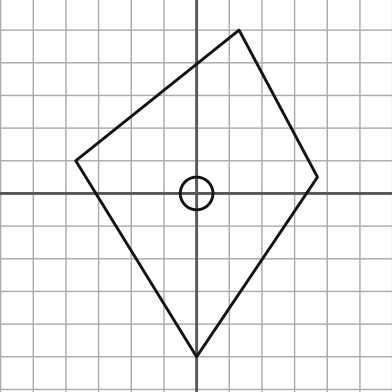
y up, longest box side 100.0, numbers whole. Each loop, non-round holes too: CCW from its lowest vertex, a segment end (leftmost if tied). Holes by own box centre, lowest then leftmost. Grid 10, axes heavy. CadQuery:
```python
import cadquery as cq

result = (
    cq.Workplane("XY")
    .moveTo(0.0, -50.0)
    .lineTo(37.0, 5.0)
    .lineTo(13.0, 50.0)
    .lineTo(-37.0, 10.0)
    .close()
    .moveTo(0.0, 0.0)
    .circle(5.0)
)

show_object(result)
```